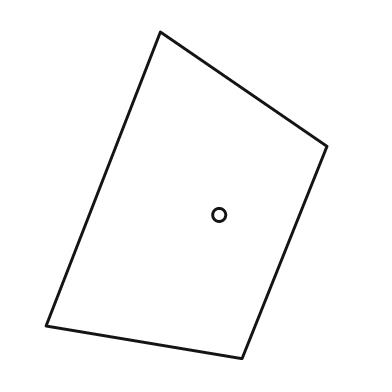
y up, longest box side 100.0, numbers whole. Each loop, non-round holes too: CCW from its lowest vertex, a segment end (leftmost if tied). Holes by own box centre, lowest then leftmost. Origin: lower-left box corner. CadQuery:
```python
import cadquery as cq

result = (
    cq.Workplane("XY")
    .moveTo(60.0, 0.0)
    .lineTo(86.0, 65.0)
    .lineTo(35.0, 100.0)
    .lineTo(0.0, 10.0)
    .close()
    .moveTo(53.0, 44.0)
    .circle(2.0)
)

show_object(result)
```